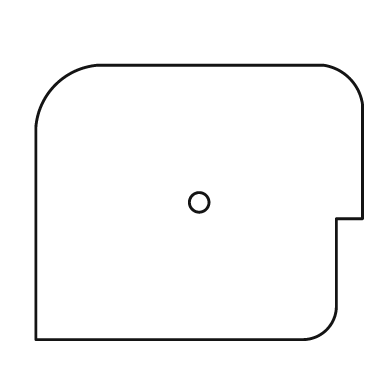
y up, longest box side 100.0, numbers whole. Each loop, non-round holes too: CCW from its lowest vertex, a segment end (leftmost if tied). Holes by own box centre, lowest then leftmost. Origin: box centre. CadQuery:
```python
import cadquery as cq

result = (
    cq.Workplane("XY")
    .moveTo(-50.0, -42.0)
    .lineTo(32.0, -42.0)
    .threePointArc((39.0, -39.0), (42.0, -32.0))
    .lineTo(42.0, -5.0)
    .lineTo(50.0, -5.0)
    .lineTo(50.0, 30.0)
    .threePointArc((46.0, 38.0), (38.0, 42.0))
    .lineTo(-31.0, 42.0)
    .threePointArc((-44.0, 36.0), (-50.0, 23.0))
    .close()
    .moveTo(0.0, 0.0)
    .circle(3.0)
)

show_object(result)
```